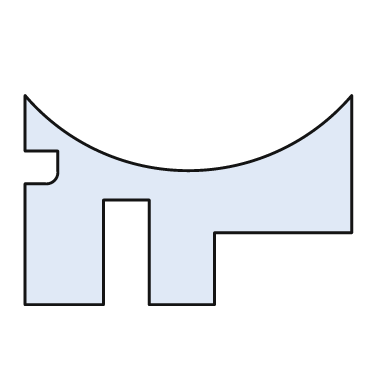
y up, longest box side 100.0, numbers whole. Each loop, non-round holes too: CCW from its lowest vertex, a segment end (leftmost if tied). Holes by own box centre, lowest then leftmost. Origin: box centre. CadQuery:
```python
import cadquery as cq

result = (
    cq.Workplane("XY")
    .moveTo(-50.0, -32.0)
    .lineTo(-26.0, -32.0)
    .lineTo(-26.0, 0.0)
    .lineTo(-12.0, 0.0)
    .lineTo(-12.0, -32.0)
    .lineTo(8.0, -32.0)
    .lineTo(8.0, -10.0)
    .lineTo(50.0, -10.0)
    .lineTo(50.0, 32.0)
    .threePointArc((0.0, 9.0), (-50.0, 32.0))
    .lineTo(-50.0, 15.0)
    .lineTo(-40.0, 15.0)
    .lineTo(-40.0, 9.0)
    .threePointArc((-41.0, 6.0), (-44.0, 5.0))
    .lineTo(-50.0, 5.0)
    .close()
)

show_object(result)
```